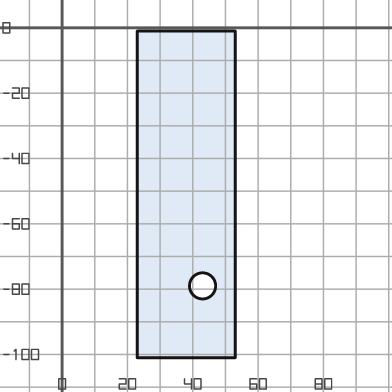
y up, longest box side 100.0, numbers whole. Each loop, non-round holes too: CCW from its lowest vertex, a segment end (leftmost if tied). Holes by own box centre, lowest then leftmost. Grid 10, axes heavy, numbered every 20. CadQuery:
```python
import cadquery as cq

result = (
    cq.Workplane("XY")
    .moveTo(23.0, -101.0)
    .lineTo(53.0, -101.0)
    .lineTo(53.0, -1.0)
    .lineTo(23.0, -1.0)
    .close()
    .moveTo(43.0, -79.0)
    .circle(4.0)
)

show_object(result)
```